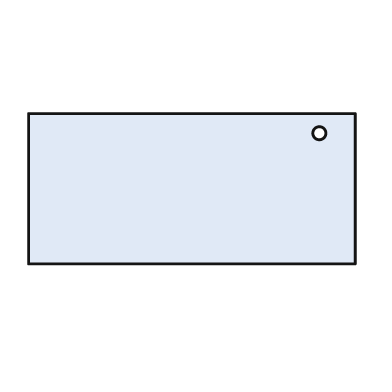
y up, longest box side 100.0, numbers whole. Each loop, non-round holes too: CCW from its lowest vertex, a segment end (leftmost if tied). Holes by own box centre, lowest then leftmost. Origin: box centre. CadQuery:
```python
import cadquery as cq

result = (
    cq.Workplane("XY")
    .moveTo(-50.0, -23.0)
    .lineTo(50.0, -23.0)
    .lineTo(50.0, 23.0)
    .lineTo(-50.0, 23.0)
    .close()
    .moveTo(39.0, 17.0)
    .circle(2.0)
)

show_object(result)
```